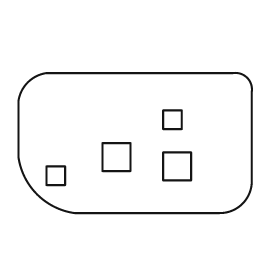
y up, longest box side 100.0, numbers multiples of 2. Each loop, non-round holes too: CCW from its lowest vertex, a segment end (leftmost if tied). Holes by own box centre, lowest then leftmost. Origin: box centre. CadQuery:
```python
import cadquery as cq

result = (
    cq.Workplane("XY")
    .moveTo(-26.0, -30.0)
    .lineTo(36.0, -30.0)
    .threePointArc((46.0, -26.0), (50.0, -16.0))
    .lineTo(50.0, 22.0)
    .threePointArc((48.0, 28.0), (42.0, 30.0))
    .lineTo(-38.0, 30.0)
    .threePointArc((-46.0, 26.0), (-50.0, 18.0))
    .lineTo(-50.0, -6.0)
    .threePointArc((-42.0, -22.0), (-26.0, -30.0))
    .close()
    .moveTo(-38.0, -18.0)
    .lineTo(-30.0, -18.0)
    .lineTo(-30.0, -10.0)
    .lineTo(-38.0, -10.0)
    .close()
    .moveTo(12.0, -16.0)
    .lineTo(24.0, -16.0)
    .lineTo(24.0, -4.0)
    .lineTo(12.0, -4.0)
    .close()
    .moveTo(-14.0, -12.0)
    .lineTo(-2.0, -12.0)
    .lineTo(-2.0, 0.0)
    .lineTo(-14.0, 0.0)
    .close()
    .moveTo(12.0, 6.0)
    .lineTo(20.0, 6.0)
    .lineTo(20.0, 14.0)
    .lineTo(12.0, 14.0)
    .close()
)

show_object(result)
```